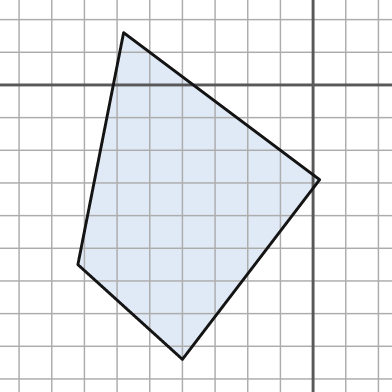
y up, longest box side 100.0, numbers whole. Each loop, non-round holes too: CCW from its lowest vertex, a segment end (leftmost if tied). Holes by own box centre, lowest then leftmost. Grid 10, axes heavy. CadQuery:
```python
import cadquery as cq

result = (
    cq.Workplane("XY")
    .moveTo(-40.0, -84.0)
    .lineTo(2.0, -29.0)
    .lineTo(-58.0, 16.0)
    .lineTo(-72.0, -55.0)
    .close()
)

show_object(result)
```